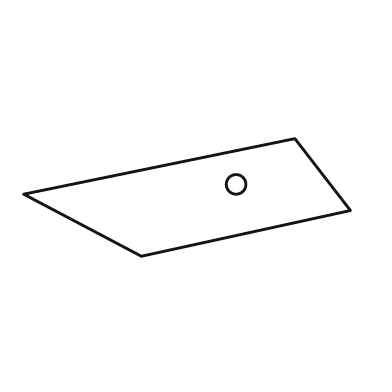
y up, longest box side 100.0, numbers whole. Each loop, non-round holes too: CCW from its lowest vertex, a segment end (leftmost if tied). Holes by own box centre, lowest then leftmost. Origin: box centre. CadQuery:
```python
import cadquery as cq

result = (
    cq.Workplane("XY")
    .moveTo(-14.0, -18.0)
    .lineTo(50.0, -4.0)
    .lineTo(33.0, 18.0)
    .lineTo(-50.0, 1.0)
    .close()
    .moveTo(15.0, 4.0)
    .circle(3.0)
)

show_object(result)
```